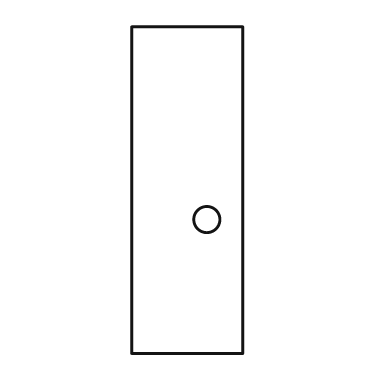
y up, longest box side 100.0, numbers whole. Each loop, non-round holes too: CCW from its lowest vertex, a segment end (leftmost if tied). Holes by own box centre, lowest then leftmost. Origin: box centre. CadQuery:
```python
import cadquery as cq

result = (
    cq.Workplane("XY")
    .moveTo(-17.0, -50.0)
    .lineTo(17.0, -50.0)
    .lineTo(17.0, 50.0)
    .lineTo(-17.0, 50.0)
    .close()
    .moveTo(6.0, -9.0)
    .circle(4.0)
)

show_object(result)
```